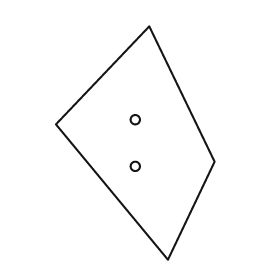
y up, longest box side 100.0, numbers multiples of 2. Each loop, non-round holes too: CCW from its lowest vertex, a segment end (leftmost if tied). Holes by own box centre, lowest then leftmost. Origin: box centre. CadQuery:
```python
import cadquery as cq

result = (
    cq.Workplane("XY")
    .moveTo(14.0, -50.0)
    .lineTo(34.0, -8.0)
    .lineTo(6.0, 50.0)
    .lineTo(-34.0, 8.0)
    .close()
    .moveTo(0.0, -10.0)
    .circle(2.0)
    .moveTo(0.0, 10.0)
    .circle(2.0)
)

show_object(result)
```